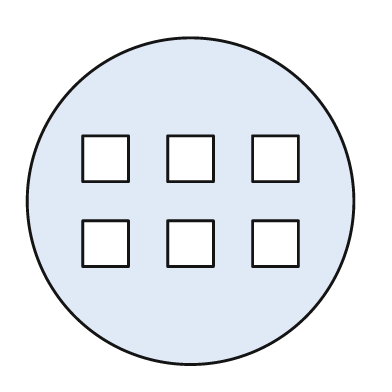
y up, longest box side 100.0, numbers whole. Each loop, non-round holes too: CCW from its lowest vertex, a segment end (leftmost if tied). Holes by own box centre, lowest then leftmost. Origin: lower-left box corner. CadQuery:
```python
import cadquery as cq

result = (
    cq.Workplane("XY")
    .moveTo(50.0, 50.0)
    .circle(50.0)
    .moveTo(17.0, 30.0)
    .lineTo(31.0, 30.0)
    .lineTo(31.0, 44.0)
    .lineTo(17.0, 44.0)
    .close()
    .moveTo(43.0, 30.0)
    .lineTo(57.0, 30.0)
    .lineTo(57.0, 44.0)
    .lineTo(43.0, 44.0)
    .close()
    .moveTo(69.0, 30.0)
    .lineTo(83.0, 30.0)
    .lineTo(83.0, 44.0)
    .lineTo(69.0, 44.0)
    .close()
    .moveTo(17.0, 56.0)
    .lineTo(31.0, 56.0)
    .lineTo(31.0, 70.0)
    .lineTo(17.0, 70.0)
    .close()
    .moveTo(43.0, 56.0)
    .lineTo(57.0, 56.0)
    .lineTo(57.0, 70.0)
    .lineTo(43.0, 70.0)
    .close()
    .moveTo(69.0, 56.0)
    .lineTo(83.0, 56.0)
    .lineTo(83.0, 70.0)
    .lineTo(69.0, 70.0)
    .close()
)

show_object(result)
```